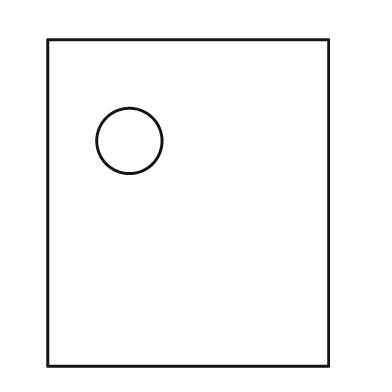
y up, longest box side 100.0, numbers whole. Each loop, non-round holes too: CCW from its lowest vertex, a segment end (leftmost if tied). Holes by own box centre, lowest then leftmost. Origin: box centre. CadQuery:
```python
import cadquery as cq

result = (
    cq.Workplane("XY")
    .moveTo(-43.0, -50.0)
    .lineTo(43.0, -50.0)
    .lineTo(43.0, 50.0)
    .lineTo(-43.0, 50.0)
    .close()
    .moveTo(-18.0, 19.0)
    .circle(10.0)
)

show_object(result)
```